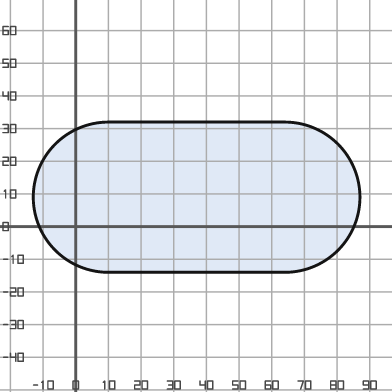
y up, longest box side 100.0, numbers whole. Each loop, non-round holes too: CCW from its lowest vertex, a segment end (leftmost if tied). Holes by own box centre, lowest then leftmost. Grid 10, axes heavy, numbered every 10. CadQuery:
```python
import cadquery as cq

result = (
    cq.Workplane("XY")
    .moveTo(10.0, -14.0)
    .lineTo(64.0, -14.0)
    .threePointArc((87.0, 9.0), (64.0, 32.0))
    .lineTo(10.0, 32.0)
    .threePointArc((-13.0, 9.0), (10.0, -14.0))
    .close()
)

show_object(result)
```